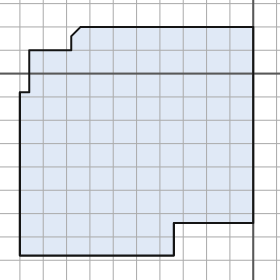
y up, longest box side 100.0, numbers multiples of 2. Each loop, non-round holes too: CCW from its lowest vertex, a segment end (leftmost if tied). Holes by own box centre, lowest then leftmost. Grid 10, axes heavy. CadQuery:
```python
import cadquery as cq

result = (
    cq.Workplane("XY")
    .moveTo(-100.0, -78.0)
    .lineTo(-34.0, -78.0)
    .lineTo(-34.0, -64.0)
    .lineTo(0.0, -64.0)
    .lineTo(0.0, 20.0)
    .lineTo(-74.0, 20.0)
    .lineTo(-78.0, 16.0)
    .lineTo(-78.0, 10.0)
    .lineTo(-96.0, 10.0)
    .lineTo(-96.0, -8.0)
    .lineTo(-100.0, -8.0)
    .close()
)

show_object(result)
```